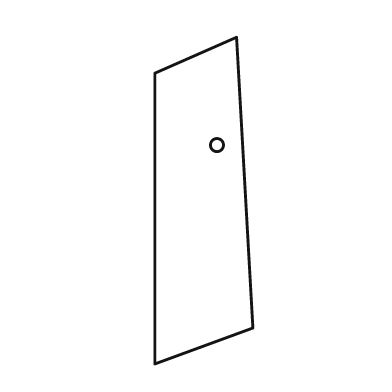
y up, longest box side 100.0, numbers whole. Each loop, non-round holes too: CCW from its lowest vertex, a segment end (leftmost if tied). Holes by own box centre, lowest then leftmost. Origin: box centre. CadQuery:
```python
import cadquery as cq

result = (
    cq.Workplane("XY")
    .moveTo(-15.0, -50.0)
    .lineTo(15.0, -39.0)
    .lineTo(10.0, 50.0)
    .lineTo(-15.0, 39.0)
    .close()
    .moveTo(4.0, 17.0)
    .circle(2.0)
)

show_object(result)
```